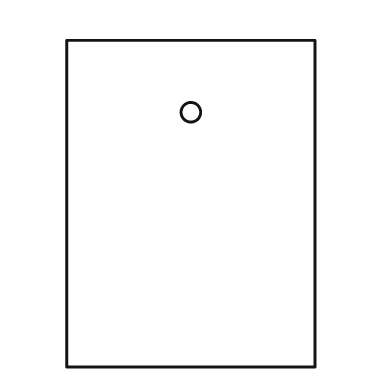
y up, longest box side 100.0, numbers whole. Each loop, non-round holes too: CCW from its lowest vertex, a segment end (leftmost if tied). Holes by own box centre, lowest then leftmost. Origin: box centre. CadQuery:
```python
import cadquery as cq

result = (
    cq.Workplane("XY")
    .moveTo(-38.0, -50.0)
    .lineTo(38.0, -50.0)
    .lineTo(38.0, 50.0)
    .lineTo(-38.0, 50.0)
    .close()
    .moveTo(0.0, 28.0)
    .circle(3.0)
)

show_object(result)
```